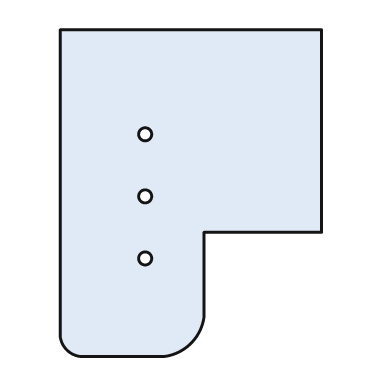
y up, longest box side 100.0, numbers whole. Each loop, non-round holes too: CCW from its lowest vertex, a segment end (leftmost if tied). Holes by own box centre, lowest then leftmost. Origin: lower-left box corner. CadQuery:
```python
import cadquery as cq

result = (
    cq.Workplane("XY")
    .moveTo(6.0, 0.0)
    .lineTo(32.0, 0.0)
    .threePointArc((40.0, 4.0), (44.0, 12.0))
    .lineTo(44.0, 38.0)
    .lineTo(80.0, 38.0)
    .lineTo(80.0, 100.0)
    .lineTo(0.0, 100.0)
    .lineTo(0.0, 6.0)
    .threePointArc((2.0, 2.0), (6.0, 0.0))
    .close()
    .moveTo(26.0, 30.0)
    .circle(2.0)
    .moveTo(26.0, 49.0)
    .circle(2.0)
    .moveTo(26.0, 68.0)
    .circle(2.0)
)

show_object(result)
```